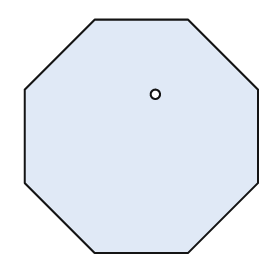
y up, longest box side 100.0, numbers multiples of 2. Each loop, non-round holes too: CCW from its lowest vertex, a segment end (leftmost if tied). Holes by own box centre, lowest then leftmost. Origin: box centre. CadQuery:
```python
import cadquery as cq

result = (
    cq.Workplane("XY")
    .moveTo(-20.0, -50.0)
    .lineTo(20.0, -50.0)
    .lineTo(50.0, -20.0)
    .lineTo(50.0, 20.0)
    .lineTo(20.0, 50.0)
    .lineTo(-20.0, 50.0)
    .lineTo(-50.0, 20.0)
    .lineTo(-50.0, -20.0)
    .close()
    .moveTo(6.0, 18.0)
    .circle(2.0)
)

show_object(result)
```